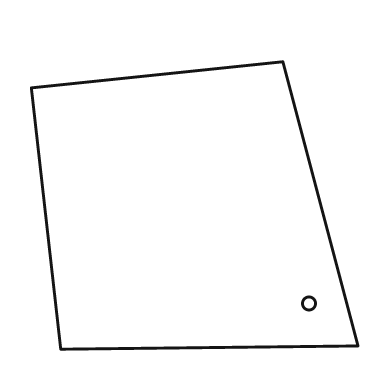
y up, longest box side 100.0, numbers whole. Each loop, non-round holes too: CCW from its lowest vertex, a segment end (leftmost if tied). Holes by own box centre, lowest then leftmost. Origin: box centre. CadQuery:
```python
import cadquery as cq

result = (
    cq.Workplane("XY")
    .moveTo(-41.0, -44.0)
    .lineTo(50.0, -43.0)
    .lineTo(27.0, 44.0)
    .lineTo(-50.0, 36.0)
    .close()
    .moveTo(35.0, -30.0)
    .circle(2.0)
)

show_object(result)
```